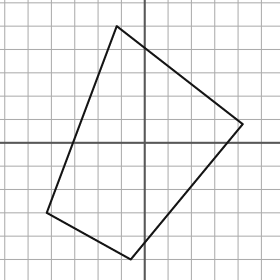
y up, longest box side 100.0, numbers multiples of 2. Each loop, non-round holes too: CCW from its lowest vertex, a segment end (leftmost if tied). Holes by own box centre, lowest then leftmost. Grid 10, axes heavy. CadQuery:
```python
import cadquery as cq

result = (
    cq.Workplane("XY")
    .moveTo(-6.0, -50.0)
    .lineTo(42.0, 8.0)
    .lineTo(-12.0, 50.0)
    .lineTo(-42.0, -30.0)
    .close()
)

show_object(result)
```